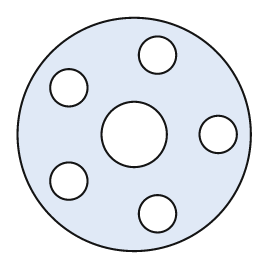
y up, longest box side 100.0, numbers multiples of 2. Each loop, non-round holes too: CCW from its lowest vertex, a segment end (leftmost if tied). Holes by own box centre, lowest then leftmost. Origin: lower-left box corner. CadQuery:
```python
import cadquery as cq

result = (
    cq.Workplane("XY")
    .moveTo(50.0, 50.0)
    .circle(50.0)
    .moveTo(60.0, 16.0)
    .circle(8.0)
    .moveTo(22.0, 30.0)
    .circle(8.0)
    .moveTo(50.0, 50.0)
    .circle(14.0)
    .moveTo(86.0, 50.0)
    .circle(8.0)
    .moveTo(22.0, 70.0)
    .circle(8.0)
    .moveTo(60.0, 84.0)
    .circle(8.0)
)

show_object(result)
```